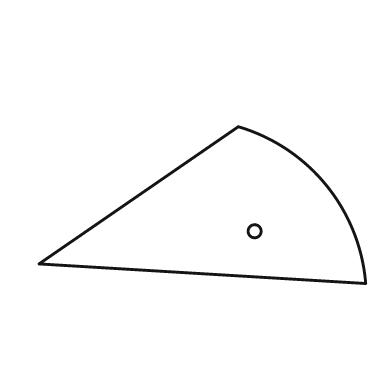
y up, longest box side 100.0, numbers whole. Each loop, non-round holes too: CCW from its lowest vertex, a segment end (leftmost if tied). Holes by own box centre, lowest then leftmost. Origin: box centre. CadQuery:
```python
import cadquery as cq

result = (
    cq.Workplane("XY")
    .moveTo(50.0, -24.0)
    .threePointArc((38.0, 6.0), (11.0, 24.0))
    .lineTo(-50.0, -18.0)
    .close()
    .moveTo(16.0, -8.0)
    .circle(2.0)
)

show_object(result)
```